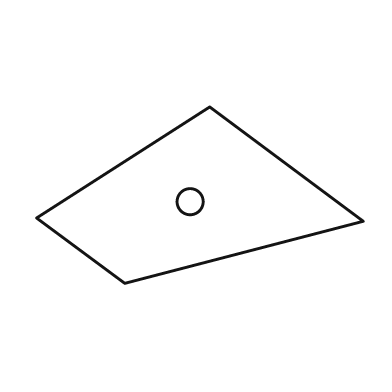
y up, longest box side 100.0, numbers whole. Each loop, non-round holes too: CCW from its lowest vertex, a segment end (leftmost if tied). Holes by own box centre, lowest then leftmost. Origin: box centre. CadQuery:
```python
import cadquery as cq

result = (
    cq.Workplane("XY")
    .moveTo(-23.0, -27.0)
    .lineTo(50.0, -8.0)
    .lineTo(3.0, 27.0)
    .lineTo(-50.0, -7.0)
    .close()
    .moveTo(-3.0, -2.0)
    .circle(4.0)
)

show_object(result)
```